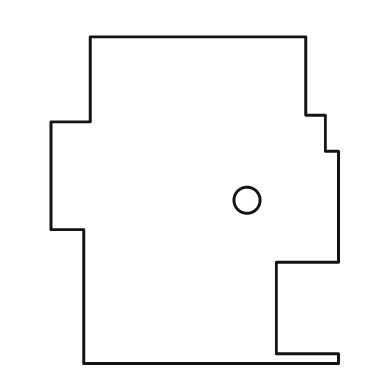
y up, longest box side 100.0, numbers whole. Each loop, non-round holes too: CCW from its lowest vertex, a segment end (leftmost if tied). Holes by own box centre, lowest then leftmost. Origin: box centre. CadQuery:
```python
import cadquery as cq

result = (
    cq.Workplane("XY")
    .moveTo(-34.0, -50.0)
    .lineTo(44.0, -50.0)
    .lineTo(44.0, -47.0)
    .lineTo(25.0, -47.0)
    .lineTo(25.0, -19.0)
    .lineTo(44.0, -19.0)
    .lineTo(44.0, 15.0)
    .lineTo(40.0, 15.0)
    .lineTo(40.0, 26.0)
    .lineTo(34.0, 26.0)
    .lineTo(34.0, 50.0)
    .lineTo(-32.0, 50.0)
    .lineTo(-32.0, 24.0)
    .lineTo(-44.0, 24.0)
    .lineTo(-44.0, -9.0)
    .lineTo(-34.0, -9.0)
    .close()
    .moveTo(16.0, 0.0)
    .circle(4.0)
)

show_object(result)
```